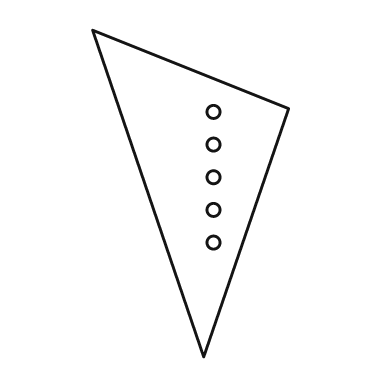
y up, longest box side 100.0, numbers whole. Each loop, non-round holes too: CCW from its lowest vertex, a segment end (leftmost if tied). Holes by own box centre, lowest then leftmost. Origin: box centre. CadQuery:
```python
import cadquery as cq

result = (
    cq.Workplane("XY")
    .moveTo(4.0, -50.0)
    .lineTo(30.0, 26.0)
    .lineTo(-30.0, 50.0)
    .close()
    .moveTo(7.0, -15.0)
    .circle(2.0)
    .moveTo(7.0, -5.0)
    .circle(2.0)
    .moveTo(7.0, 5.0)
    .circle(2.0)
    .moveTo(7.0, 15.0)
    .circle(2.0)
    .moveTo(7.0, 25.0)
    .circle(2.0)
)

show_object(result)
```